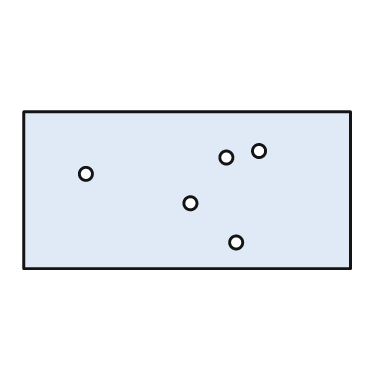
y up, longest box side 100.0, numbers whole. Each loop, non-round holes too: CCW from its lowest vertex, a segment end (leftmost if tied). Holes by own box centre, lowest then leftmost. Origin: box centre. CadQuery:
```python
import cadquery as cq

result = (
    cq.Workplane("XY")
    .moveTo(-50.0, -24.0)
    .lineTo(50.0, -24.0)
    .lineTo(50.0, 24.0)
    .lineTo(-50.0, 24.0)
    .close()
    .moveTo(15.0, -16.0)
    .circle(2.0)
    .moveTo(1.0, -4.0)
    .circle(2.0)
    .moveTo(-31.0, 5.0)
    .circle(2.0)
    .moveTo(12.0, 10.0)
    .circle(2.0)
    .moveTo(22.0, 12.0)
    .circle(2.0)
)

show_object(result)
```